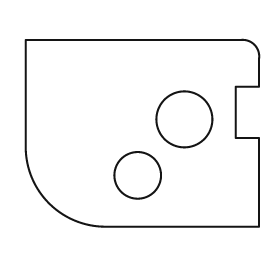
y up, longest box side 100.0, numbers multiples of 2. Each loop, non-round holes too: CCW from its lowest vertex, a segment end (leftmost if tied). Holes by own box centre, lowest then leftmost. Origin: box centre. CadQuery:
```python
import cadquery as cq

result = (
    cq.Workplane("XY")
    .moveTo(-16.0, -40.0)
    .lineTo(50.0, -40.0)
    .lineTo(50.0, -2.0)
    .lineTo(40.0, -2.0)
    .lineTo(40.0, 20.0)
    .lineTo(50.0, 20.0)
    .lineTo(50.0, 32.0)
    .threePointArc((48.0, 38.0), (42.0, 40.0))
    .lineTo(-50.0, 40.0)
    .lineTo(-50.0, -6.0)
    .threePointArc((-40.0, -30.0), (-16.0, -40.0))
    .close()
    .moveTo(-2.0, -18.0)
    .circle(10.0)
    .moveTo(18.0, 6.0)
    .circle(12.0)
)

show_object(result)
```